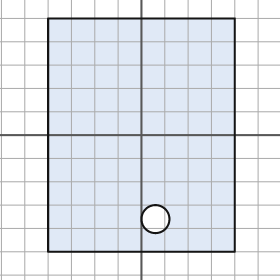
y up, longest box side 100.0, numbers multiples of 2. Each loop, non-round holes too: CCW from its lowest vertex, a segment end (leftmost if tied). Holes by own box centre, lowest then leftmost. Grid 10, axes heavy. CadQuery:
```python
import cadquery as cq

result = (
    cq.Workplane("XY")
    .moveTo(-40.0, -50.0)
    .lineTo(40.0, -50.0)
    .lineTo(40.0, 50.0)
    .lineTo(-40.0, 50.0)
    .close()
    .moveTo(6.0, -36.0)
    .circle(6.0)
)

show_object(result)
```